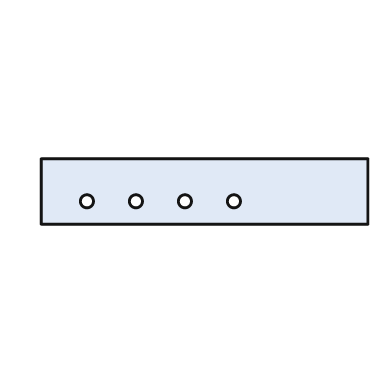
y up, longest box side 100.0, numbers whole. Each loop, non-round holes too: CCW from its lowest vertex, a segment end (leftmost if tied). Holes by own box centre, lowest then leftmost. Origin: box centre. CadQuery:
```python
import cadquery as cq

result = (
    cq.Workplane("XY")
    .moveTo(-50.0, -10.0)
    .lineTo(50.0, -10.0)
    .lineTo(50.0, 10.0)
    .lineTo(-50.0, 10.0)
    .close()
    .moveTo(-36.0, -3.0)
    .circle(2.0)
    .moveTo(-21.0, -3.0)
    .circle(2.0)
    .moveTo(-6.0, -3.0)
    .circle(2.0)
    .moveTo(9.0, -3.0)
    .circle(2.0)
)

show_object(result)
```